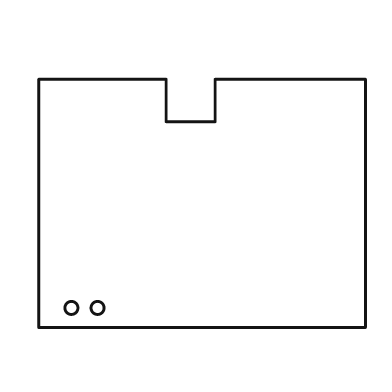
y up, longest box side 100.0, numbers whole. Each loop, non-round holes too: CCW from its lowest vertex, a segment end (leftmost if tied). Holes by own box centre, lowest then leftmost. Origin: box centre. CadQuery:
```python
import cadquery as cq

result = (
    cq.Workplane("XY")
    .moveTo(-50.0, -38.0)
    .lineTo(50.0, -38.0)
    .lineTo(50.0, 38.0)
    .lineTo(4.0, 38.0)
    .lineTo(4.0, 25.0)
    .lineTo(-11.0, 25.0)
    .lineTo(-11.0, 38.0)
    .lineTo(-50.0, 38.0)
    .close()
    .moveTo(-40.0, -32.0)
    .circle(2.0)
    .moveTo(-32.0, -32.0)
    .circle(2.0)
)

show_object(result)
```